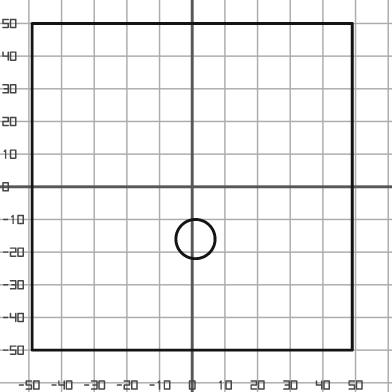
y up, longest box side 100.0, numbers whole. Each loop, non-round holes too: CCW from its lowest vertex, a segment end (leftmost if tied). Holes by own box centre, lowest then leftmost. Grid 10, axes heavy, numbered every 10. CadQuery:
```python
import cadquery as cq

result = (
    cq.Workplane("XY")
    .moveTo(-49.0, -50.0)
    .lineTo(49.0, -50.0)
    .lineTo(49.0, 50.0)
    .lineTo(-49.0, 50.0)
    .close()
    .moveTo(1.0, -16.0)
    .circle(6.0)
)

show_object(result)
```